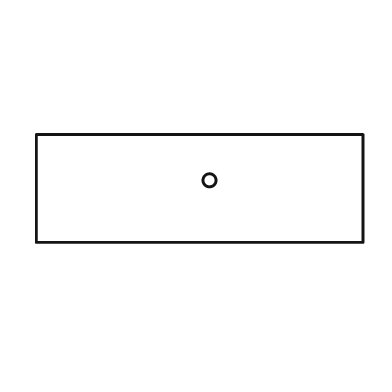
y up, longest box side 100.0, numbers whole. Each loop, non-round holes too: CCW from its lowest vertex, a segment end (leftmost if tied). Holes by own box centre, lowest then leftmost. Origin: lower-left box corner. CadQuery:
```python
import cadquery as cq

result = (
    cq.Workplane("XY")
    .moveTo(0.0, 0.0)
    .lineTo(100.0, 0.0)
    .lineTo(100.0, 33.0)
    .lineTo(0.0, 33.0)
    .close()
    .moveTo(53.0, 19.0)
    .circle(2.0)
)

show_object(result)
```